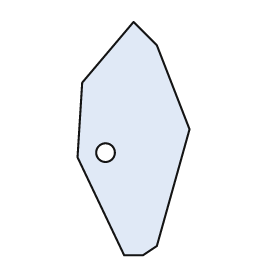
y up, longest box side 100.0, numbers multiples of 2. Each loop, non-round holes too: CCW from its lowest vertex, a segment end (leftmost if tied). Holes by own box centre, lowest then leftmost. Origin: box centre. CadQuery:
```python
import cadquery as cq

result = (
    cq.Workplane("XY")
    .moveTo(-4.0, -50.0)
    .lineTo(4.0, -50.0)
    .lineTo(10.0, -46.0)
    .lineTo(24.0, 4.0)
    .lineTo(10.0, 40.0)
    .lineTo(0.0, 50.0)
    .lineTo(-22.0, 24.0)
    .lineTo(-24.0, -8.0)
    .close()
    .moveTo(-12.0, -6.0)
    .circle(4.0)
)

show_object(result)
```